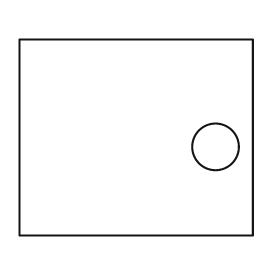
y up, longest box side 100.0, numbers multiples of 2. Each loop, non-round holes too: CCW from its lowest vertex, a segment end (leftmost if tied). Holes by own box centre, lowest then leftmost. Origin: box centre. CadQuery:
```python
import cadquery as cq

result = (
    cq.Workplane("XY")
    .moveTo(-50.0, -42.0)
    .lineTo(50.0, -42.0)
    .lineTo(50.0, 42.0)
    .lineTo(-50.0, 42.0)
    .close()
    .moveTo(34.0, -4.0)
    .circle(10.0)
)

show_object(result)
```